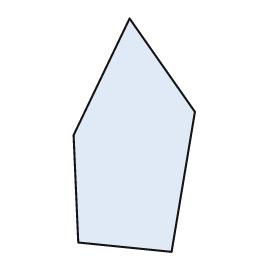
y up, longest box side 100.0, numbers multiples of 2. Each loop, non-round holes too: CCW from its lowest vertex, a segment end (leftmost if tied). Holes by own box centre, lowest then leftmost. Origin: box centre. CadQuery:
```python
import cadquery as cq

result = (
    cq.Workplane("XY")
    .moveTo(16.0, -50.0)
    .lineTo(26.0, 10.0)
    .lineTo(-2.0, 50.0)
    .lineTo(-26.0, 0.0)
    .lineTo(-24.0, -46.0)
    .close()
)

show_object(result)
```